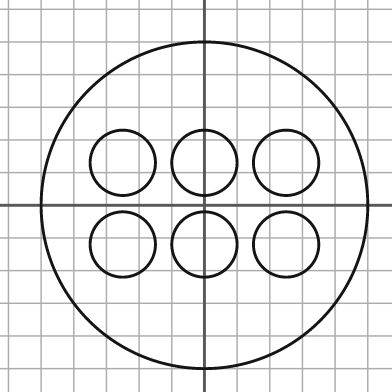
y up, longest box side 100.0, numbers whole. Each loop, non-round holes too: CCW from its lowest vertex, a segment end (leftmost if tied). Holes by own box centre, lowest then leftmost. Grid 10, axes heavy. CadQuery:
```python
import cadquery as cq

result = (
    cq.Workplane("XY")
    .moveTo(0.0, 0.0)
    .circle(50.0)
    .moveTo(-25.0, -12.0)
    .circle(10.0)
    .moveTo(0.0, -12.0)
    .circle(10.0)
    .moveTo(25.0, -12.0)
    .circle(10.0)
    .moveTo(-25.0, 13.0)
    .circle(10.0)
    .moveTo(0.0, 13.0)
    .circle(10.0)
    .moveTo(25.0, 13.0)
    .circle(10.0)
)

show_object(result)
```